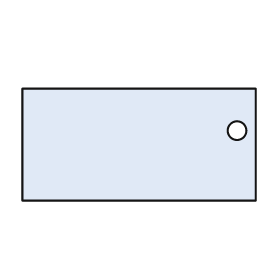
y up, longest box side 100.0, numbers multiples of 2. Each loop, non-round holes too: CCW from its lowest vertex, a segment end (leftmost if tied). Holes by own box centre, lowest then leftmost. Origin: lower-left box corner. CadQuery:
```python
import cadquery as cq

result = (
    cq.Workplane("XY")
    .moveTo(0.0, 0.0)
    .lineTo(100.0, 0.0)
    .lineTo(100.0, 48.0)
    .lineTo(0.0, 48.0)
    .close()
    .moveTo(92.0, 30.0)
    .circle(4.0)
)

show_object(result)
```